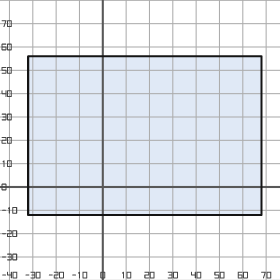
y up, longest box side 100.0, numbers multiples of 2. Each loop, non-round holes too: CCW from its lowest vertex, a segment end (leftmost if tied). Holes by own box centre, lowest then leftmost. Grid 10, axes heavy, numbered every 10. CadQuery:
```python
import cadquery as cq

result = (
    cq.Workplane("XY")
    .moveTo(-32.0, -12.0)
    .lineTo(68.0, -12.0)
    .lineTo(68.0, 56.0)
    .lineTo(-32.0, 56.0)
    .close()
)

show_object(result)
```